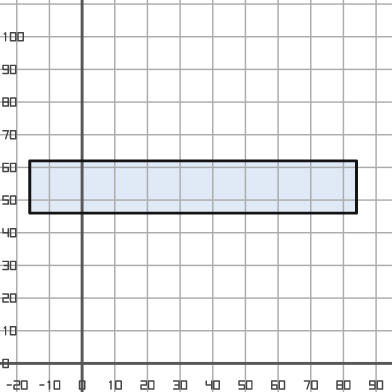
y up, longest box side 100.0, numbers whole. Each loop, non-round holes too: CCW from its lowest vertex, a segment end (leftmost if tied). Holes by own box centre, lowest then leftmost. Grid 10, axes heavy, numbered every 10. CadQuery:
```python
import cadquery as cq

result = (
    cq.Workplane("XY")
    .moveTo(-16.0, 46.0)
    .lineTo(84.0, 46.0)
    .lineTo(84.0, 62.0)
    .lineTo(-16.0, 62.0)
    .close()
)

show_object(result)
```